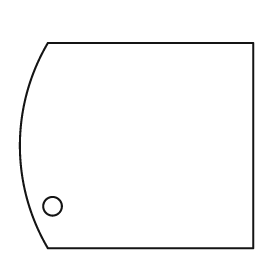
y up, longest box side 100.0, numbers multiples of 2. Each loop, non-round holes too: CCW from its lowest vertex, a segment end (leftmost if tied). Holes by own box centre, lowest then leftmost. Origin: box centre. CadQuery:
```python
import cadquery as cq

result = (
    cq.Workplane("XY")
    .moveTo(-38.0, -44.0)
    .lineTo(50.0, -44.0)
    .lineTo(50.0, 44.0)
    .lineTo(-38.0, 44.0)
    .threePointArc((-50.0, 0.0), (-38.0, -44.0))
    .close()
    .moveTo(-36.0, -26.0)
    .circle(4.0)
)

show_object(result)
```